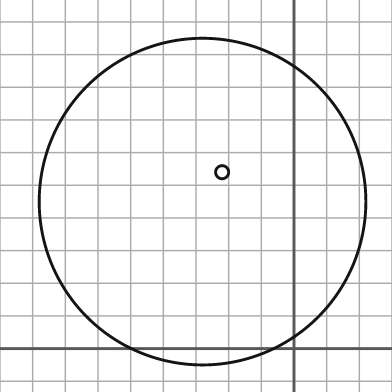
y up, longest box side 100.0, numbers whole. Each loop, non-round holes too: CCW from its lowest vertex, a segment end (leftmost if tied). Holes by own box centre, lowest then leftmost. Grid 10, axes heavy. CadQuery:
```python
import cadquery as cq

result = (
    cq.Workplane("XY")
    .moveTo(-28.0, 45.0)
    .circle(50.0)
    .moveTo(-22.0, 54.0)
    .circle(2.0)
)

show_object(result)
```